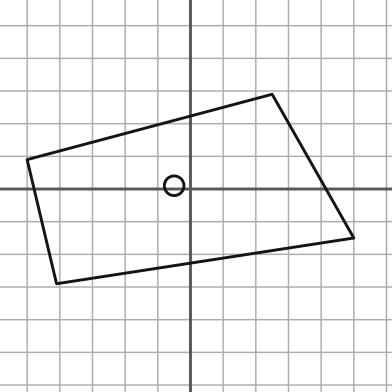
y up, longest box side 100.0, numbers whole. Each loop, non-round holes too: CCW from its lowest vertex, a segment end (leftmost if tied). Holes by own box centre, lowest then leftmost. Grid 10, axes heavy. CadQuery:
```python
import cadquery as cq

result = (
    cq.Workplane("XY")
    .moveTo(-41.0, -29.0)
    .lineTo(50.0, -15.0)
    .lineTo(25.0, 29.0)
    .lineTo(-50.0, 9.0)
    .close()
    .moveTo(-5.0, 1.0)
    .circle(3.0)
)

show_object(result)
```